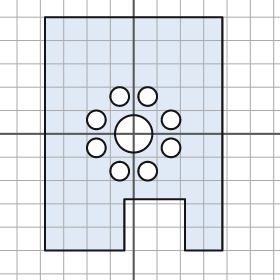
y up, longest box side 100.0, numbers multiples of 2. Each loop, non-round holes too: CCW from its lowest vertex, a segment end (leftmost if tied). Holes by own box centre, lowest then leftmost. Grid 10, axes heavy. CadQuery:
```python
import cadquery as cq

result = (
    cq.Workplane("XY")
    .moveTo(-38.0, -50.0)
    .lineTo(-4.0, -50.0)
    .lineTo(-4.0, -28.0)
    .lineTo(22.0, -28.0)
    .lineTo(22.0, -50.0)
    .lineTo(38.0, -50.0)
    .lineTo(38.0, 50.0)
    .lineTo(-38.0, 50.0)
    .close()
    .moveTo(-6.0, -16.0)
    .circle(4.0)
    .moveTo(6.0, -16.0)
    .circle(4.0)
    .moveTo(-16.0, -6.0)
    .circle(4.0)
    .moveTo(16.0, -6.0)
    .circle(4.0)
    .moveTo(0.0, 0.0)
    .circle(8.0)
    .moveTo(-16.0, 6.0)
    .circle(4.0)
    .moveTo(16.0, 6.0)
    .circle(4.0)
    .moveTo(-6.0, 16.0)
    .circle(4.0)
    .moveTo(6.0, 16.0)
    .circle(4.0)
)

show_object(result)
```